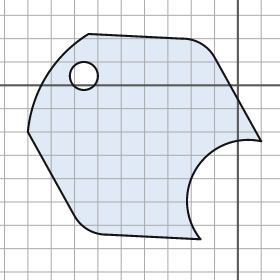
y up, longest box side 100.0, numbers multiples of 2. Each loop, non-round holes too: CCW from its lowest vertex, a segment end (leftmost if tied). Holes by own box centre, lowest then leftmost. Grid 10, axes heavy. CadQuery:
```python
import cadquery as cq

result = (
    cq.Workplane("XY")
    .moveTo(-16.0, -66.0)
    .threePointArc((-18.0, -36.0), (10.0, -24.0))
    .lineTo(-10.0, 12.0)
    .threePointArc((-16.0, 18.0), (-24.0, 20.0))
    .lineTo(-64.0, 22.0)
    .threePointArc((-82.0, 4.0), (-90.0, -20.0))
    .lineTo(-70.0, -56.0)
    .threePointArc((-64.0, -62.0), (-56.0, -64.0))
    .close()
    .moveTo(-66.0, 4.0)
    .circle(6.0)
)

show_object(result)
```